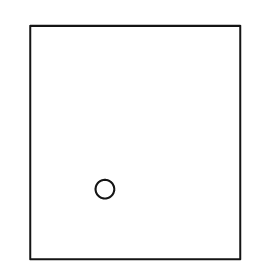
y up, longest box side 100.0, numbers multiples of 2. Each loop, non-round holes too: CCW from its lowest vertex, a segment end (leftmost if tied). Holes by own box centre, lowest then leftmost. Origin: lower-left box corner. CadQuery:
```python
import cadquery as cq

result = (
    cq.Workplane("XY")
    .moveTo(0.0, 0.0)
    .lineTo(90.0, 0.0)
    .lineTo(90.0, 100.0)
    .lineTo(0.0, 100.0)
    .close()
    .moveTo(32.0, 30.0)
    .circle(4.0)
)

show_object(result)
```